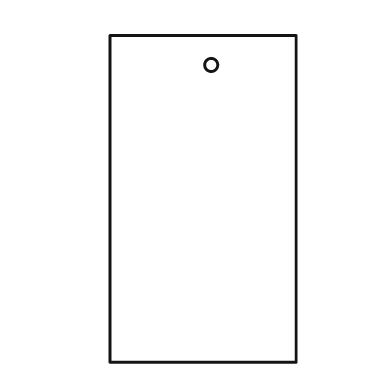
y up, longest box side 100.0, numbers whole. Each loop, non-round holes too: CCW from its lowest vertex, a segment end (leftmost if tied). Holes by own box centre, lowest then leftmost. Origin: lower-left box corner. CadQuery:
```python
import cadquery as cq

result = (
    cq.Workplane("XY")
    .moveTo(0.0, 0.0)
    .lineTo(57.0, 0.0)
    .lineTo(57.0, 100.0)
    .lineTo(0.0, 100.0)
    .close()
    .moveTo(31.0, 91.0)
    .circle(2.0)
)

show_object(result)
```